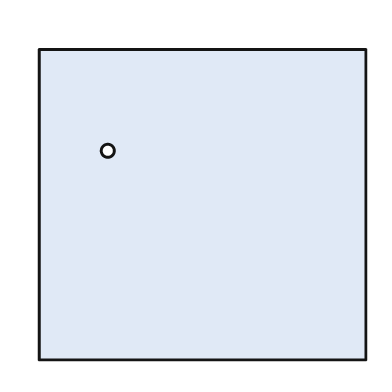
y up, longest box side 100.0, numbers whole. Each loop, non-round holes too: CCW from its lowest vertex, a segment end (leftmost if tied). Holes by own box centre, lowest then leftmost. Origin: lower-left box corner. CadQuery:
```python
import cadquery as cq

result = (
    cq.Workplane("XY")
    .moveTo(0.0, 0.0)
    .lineTo(100.0, 0.0)
    .lineTo(100.0, 95.0)
    .lineTo(0.0, 95.0)
    .close()
    .moveTo(21.0, 64.0)
    .circle(2.0)
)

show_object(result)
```